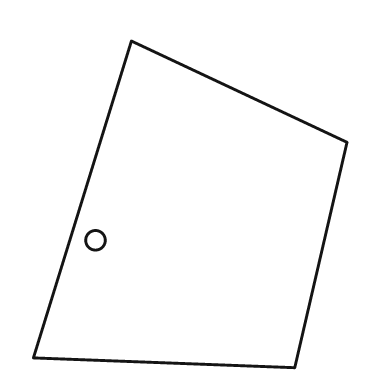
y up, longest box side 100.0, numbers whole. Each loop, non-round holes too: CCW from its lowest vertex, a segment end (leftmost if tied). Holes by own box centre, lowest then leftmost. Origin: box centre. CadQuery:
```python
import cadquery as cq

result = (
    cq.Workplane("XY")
    .moveTo(32.0, -50.0)
    .lineTo(48.0, 19.0)
    .lineTo(-18.0, 50.0)
    .lineTo(-48.0, -47.0)
    .close()
    .moveTo(-29.0, -11.0)
    .circle(3.0)
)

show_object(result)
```